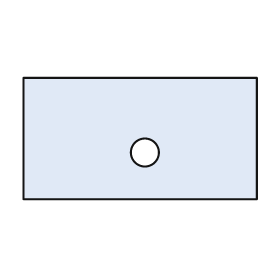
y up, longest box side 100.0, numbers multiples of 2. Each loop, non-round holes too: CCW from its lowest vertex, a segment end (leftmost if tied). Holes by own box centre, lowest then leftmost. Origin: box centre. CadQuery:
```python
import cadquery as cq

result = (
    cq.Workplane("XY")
    .moveTo(-50.0, -26.0)
    .lineTo(50.0, -26.0)
    .lineTo(50.0, 26.0)
    .lineTo(-50.0, 26.0)
    .close()
    .moveTo(2.0, -6.0)
    .circle(6.0)
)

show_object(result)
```